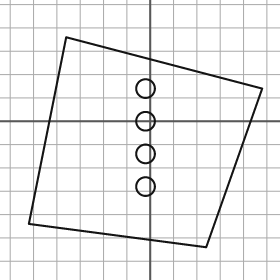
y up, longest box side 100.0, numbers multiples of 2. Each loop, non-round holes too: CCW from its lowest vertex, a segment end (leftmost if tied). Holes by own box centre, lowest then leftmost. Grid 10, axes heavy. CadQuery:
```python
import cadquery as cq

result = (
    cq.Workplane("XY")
    .moveTo(24.0, -54.0)
    .lineTo(48.0, 14.0)
    .lineTo(-36.0, 36.0)
    .lineTo(-52.0, -44.0)
    .close()
    .moveTo(-2.0, -28.0)
    .circle(4.0)
    .moveTo(-2.0, -14.0)
    .circle(4.0)
    .moveTo(-2.0, 0.0)
    .circle(4.0)
    .moveTo(-2.0, 14.0)
    .circle(4.0)
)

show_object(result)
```